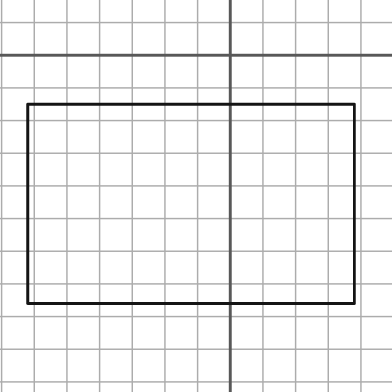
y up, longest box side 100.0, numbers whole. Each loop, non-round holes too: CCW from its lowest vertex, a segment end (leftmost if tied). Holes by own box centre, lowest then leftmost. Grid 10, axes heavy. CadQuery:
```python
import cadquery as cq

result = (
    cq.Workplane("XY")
    .moveTo(-62.0, -76.0)
    .lineTo(38.0, -76.0)
    .lineTo(38.0, -15.0)
    .lineTo(-62.0, -15.0)
    .close()
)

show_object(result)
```